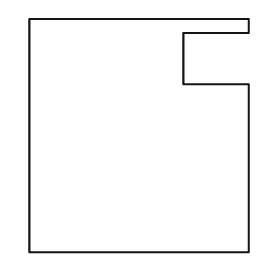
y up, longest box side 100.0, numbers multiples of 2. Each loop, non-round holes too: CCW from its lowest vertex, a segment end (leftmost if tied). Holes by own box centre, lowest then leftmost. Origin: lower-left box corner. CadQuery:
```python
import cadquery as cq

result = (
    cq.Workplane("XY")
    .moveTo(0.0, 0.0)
    .lineTo(94.0, 0.0)
    .lineTo(94.0, 72.0)
    .lineTo(66.0, 72.0)
    .lineTo(66.0, 94.0)
    .lineTo(94.0, 94.0)
    .lineTo(94.0, 100.0)
    .lineTo(0.0, 100.0)
    .close()
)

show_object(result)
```